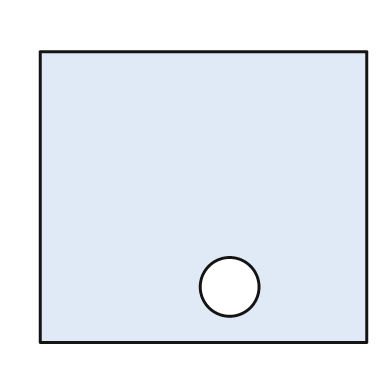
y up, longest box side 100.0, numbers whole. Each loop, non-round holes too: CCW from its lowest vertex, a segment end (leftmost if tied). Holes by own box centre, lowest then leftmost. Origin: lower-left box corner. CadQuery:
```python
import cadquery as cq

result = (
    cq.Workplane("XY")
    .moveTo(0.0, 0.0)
    .lineTo(100.0, 0.0)
    .lineTo(100.0, 89.0)
    .lineTo(0.0, 89.0)
    .close()
    .moveTo(58.0, 17.0)
    .circle(9.0)
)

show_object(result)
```